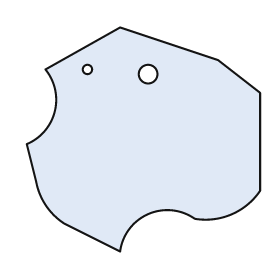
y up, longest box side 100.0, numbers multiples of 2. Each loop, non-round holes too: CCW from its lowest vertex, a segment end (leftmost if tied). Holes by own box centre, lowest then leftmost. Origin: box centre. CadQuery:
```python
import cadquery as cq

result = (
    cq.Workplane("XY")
    .moveTo(-10.0, -48.0)
    .threePointArc((2.0, -32.0), (22.0, -34.0))
    .threePointArc((38.0, -32.0), (50.0, -22.0))
    .lineTo(50.0, 20.0)
    .lineTo(32.0, 34.0)
    .lineTo(-10.0, 48.0)
    .lineTo(-42.0, 30.0)
    .threePointArc((-38.0, 12.0), (-50.0, -2.0))
    .lineTo(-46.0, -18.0)
    .threePointArc((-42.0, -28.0), (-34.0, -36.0))
    .close()
    .moveTo(2.0, 28.0)
    .circle(4.0)
    .moveTo(-24.0, 30.0)
    .circle(2.0)
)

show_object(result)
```